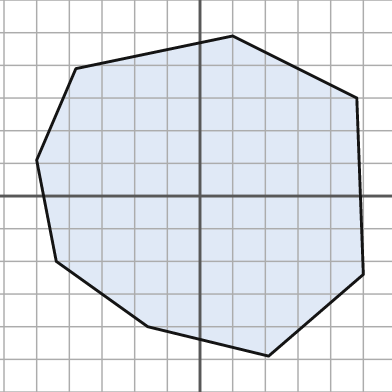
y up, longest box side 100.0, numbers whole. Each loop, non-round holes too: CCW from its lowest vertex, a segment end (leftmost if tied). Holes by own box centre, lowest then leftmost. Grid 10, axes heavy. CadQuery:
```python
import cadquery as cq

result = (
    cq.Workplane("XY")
    .moveTo(21.0, -49.0)
    .lineTo(50.0, -24.0)
    .lineTo(48.0, 30.0)
    .lineTo(10.0, 49.0)
    .lineTo(-38.0, 39.0)
    .lineTo(-50.0, 11.0)
    .lineTo(-44.0, -20.0)
    .lineTo(-16.0, -40.0)
    .close()
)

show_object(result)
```